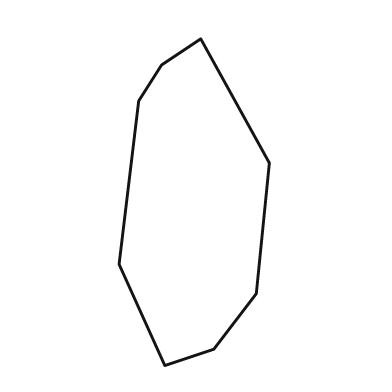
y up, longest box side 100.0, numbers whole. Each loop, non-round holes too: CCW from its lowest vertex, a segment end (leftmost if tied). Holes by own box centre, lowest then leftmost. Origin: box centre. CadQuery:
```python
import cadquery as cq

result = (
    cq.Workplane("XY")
    .moveTo(-9.0, -50.0)
    .lineTo(6.0, -45.0)
    .lineTo(19.0, -28.0)
    .lineTo(23.0, 12.0)
    .lineTo(2.0, 50.0)
    .lineTo(-10.0, 42.0)
    .lineTo(-17.0, 31.0)
    .lineTo(-23.0, -19.0)
    .close()
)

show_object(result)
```